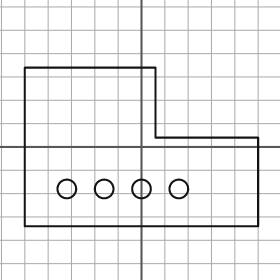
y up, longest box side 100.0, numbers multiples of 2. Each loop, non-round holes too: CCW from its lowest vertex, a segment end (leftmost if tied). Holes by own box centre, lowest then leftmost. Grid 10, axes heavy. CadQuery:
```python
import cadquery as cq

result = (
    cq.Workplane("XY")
    .moveTo(-50.0, -34.0)
    .lineTo(50.0, -34.0)
    .lineTo(50.0, 4.0)
    .lineTo(6.0, 4.0)
    .lineTo(6.0, 34.0)
    .lineTo(-50.0, 34.0)
    .close()
    .moveTo(-32.0, -18.0)
    .circle(4.0)
    .moveTo(-16.0, -18.0)
    .circle(4.0)
    .moveTo(0.0, -18.0)
    .circle(4.0)
    .moveTo(16.0, -18.0)
    .circle(4.0)
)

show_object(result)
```